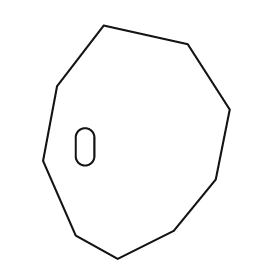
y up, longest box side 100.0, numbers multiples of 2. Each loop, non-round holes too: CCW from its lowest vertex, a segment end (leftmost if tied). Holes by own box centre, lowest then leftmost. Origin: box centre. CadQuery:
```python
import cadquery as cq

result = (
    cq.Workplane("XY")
    .moveTo(-8.0, -50.0)
    .lineTo(16.0, -38.0)
    .lineTo(34.0, -16.0)
    .lineTo(40.0, 14.0)
    .lineTo(22.0, 42.0)
    .lineTo(-14.0, 50.0)
    .lineTo(-34.0, 24.0)
    .lineTo(-40.0, -8.0)
    .lineTo(-26.0, -40.0)
    .close()
    .moveTo(-26.0, -6.0)
    .threePointArc((-22.0, -10.0), (-18.0, -6.0))
    .lineTo(-18.0, 2.0)
    .threePointArc((-22.0, 6.0), (-26.0, 2.0))
    .close()
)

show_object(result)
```